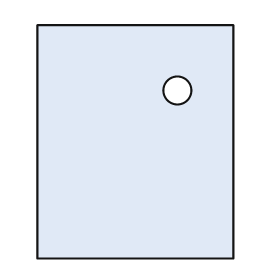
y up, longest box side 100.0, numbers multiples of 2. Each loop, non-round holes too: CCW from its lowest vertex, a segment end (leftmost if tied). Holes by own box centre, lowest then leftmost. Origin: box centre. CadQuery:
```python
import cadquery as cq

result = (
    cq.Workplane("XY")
    .moveTo(-42.0, -50.0)
    .lineTo(42.0, -50.0)
    .lineTo(42.0, 50.0)
    .lineTo(-42.0, 50.0)
    .close()
    .moveTo(18.0, 22.0)
    .circle(6.0)
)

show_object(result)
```